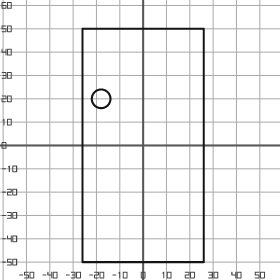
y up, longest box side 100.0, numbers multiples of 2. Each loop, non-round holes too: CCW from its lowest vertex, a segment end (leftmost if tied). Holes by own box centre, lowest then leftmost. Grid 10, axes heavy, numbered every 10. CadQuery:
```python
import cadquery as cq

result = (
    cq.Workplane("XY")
    .moveTo(-26.0, -50.0)
    .lineTo(26.0, -50.0)
    .lineTo(26.0, 50.0)
    .lineTo(-26.0, 50.0)
    .close()
    .moveTo(-18.0, 20.0)
    .circle(4.0)
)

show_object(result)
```